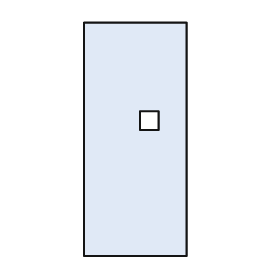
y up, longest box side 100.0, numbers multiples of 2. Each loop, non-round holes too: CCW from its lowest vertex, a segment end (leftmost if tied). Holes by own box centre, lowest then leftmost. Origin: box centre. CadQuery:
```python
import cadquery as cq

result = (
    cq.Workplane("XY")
    .moveTo(-22.0, -50.0)
    .lineTo(22.0, -50.0)
    .lineTo(22.0, 50.0)
    .lineTo(-22.0, 50.0)
    .close()
    .moveTo(2.0, 4.0)
    .lineTo(10.0, 4.0)
    .lineTo(10.0, 12.0)
    .lineTo(2.0, 12.0)
    .close()
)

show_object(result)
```